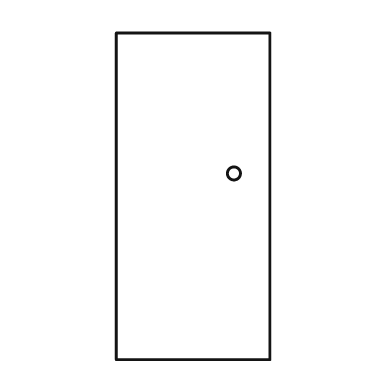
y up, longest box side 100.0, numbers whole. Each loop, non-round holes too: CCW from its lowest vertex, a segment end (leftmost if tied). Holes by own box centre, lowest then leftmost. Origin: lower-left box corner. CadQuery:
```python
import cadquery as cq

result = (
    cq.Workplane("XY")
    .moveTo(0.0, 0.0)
    .lineTo(47.0, 0.0)
    .lineTo(47.0, 100.0)
    .lineTo(0.0, 100.0)
    .close()
    .moveTo(36.0, 57.0)
    .circle(2.0)
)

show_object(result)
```